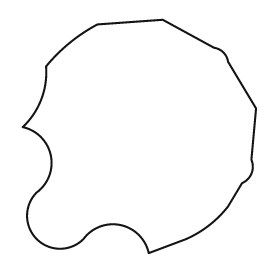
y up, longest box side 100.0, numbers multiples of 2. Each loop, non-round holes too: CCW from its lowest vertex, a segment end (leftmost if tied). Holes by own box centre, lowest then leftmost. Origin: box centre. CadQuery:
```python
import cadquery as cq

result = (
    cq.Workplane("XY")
    .moveTo(4.0, -50.0)
    .lineTo(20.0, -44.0)
    .threePointArc((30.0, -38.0), (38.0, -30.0))
    .lineTo(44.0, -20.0)
    .threePointArc((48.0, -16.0), (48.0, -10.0))
    .lineTo(50.0, 12.0)
    .lineTo(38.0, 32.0)
    .threePointArc((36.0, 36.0), (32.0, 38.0))
    .lineTo(10.0, 50.0)
    .lineTo(-18.0, 48.0)
    .threePointArc((-30.0, 40.0), (-40.0, 30.0))
    .threePointArc((-42.0, 16.0), (-50.0, 4.0))
    .threePointArc((-38.0, -8.0), (-44.0, -24.0))
    .threePointArc((-44.0, -44.0), (-24.0, -44.0))
    .threePointArc((-8.0, -38.0), (4.0, -50.0))
    .close()
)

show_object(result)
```